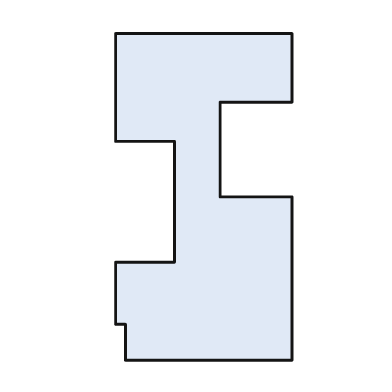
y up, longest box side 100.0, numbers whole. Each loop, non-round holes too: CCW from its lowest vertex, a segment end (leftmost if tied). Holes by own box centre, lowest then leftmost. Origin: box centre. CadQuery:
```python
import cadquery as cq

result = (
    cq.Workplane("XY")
    .moveTo(-24.0, -50.0)
    .lineTo(27.0, -50.0)
    .lineTo(27.0, 0.0)
    .lineTo(5.0, 0.0)
    .lineTo(5.0, 29.0)
    .lineTo(27.0, 29.0)
    .lineTo(27.0, 50.0)
    .lineTo(-27.0, 50.0)
    .lineTo(-27.0, 17.0)
    .lineTo(-9.0, 17.0)
    .lineTo(-9.0, -20.0)
    .lineTo(-27.0, -20.0)
    .lineTo(-27.0, -39.0)
    .lineTo(-24.0, -39.0)
    .close()
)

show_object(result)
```